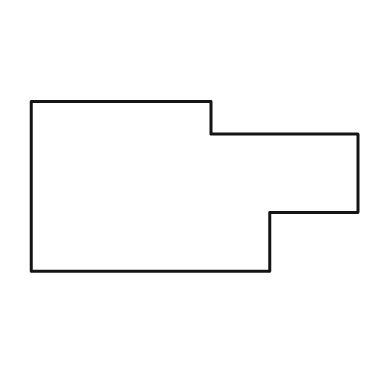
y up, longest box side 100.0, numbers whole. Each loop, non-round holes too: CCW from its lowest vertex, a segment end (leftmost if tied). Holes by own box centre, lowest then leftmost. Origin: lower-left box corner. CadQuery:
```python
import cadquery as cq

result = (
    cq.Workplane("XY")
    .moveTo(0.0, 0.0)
    .lineTo(73.0, 0.0)
    .lineTo(73.0, 18.0)
    .lineTo(100.0, 18.0)
    .lineTo(100.0, 42.0)
    .lineTo(55.0, 42.0)
    .lineTo(55.0, 52.0)
    .lineTo(0.0, 52.0)
    .close()
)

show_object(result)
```